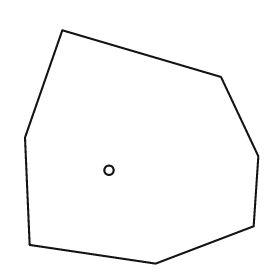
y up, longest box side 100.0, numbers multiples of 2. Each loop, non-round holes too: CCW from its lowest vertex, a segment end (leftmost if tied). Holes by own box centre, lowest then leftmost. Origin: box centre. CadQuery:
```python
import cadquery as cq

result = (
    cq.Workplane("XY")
    .moveTo(6.0, -50.0)
    .lineTo(48.0, -34.0)
    .lineTo(50.0, -4.0)
    .lineTo(34.0, 30.0)
    .lineTo(-34.0, 50.0)
    .lineTo(-50.0, 4.0)
    .lineTo(-48.0, -42.0)
    .close()
    .moveTo(-14.0, -10.0)
    .circle(2.0)
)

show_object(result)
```